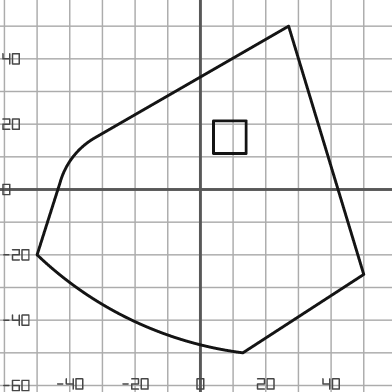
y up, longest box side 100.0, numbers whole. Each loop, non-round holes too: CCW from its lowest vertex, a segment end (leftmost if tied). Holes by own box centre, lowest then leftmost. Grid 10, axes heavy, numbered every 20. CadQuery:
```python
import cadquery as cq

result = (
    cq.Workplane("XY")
    .moveTo(13.0, -50.0)
    .lineTo(50.0, -26.0)
    .lineTo(27.0, 50.0)
    .lineTo(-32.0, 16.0)
    .threePointArc((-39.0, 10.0), (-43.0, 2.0))
    .lineTo(-50.0, -20.0)
    .threePointArc((-21.0, -40.0), (13.0, -50.0))
    .close()
    .moveTo(4.0, 11.0)
    .lineTo(14.0, 11.0)
    .lineTo(14.0, 21.0)
    .lineTo(4.0, 21.0)
    .close()
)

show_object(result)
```